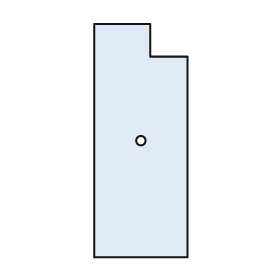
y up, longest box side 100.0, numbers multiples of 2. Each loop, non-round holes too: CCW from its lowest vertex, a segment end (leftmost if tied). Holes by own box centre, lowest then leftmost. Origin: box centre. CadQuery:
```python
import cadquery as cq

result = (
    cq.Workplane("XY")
    .moveTo(-20.0, -50.0)
    .lineTo(20.0, -50.0)
    .lineTo(20.0, 36.0)
    .lineTo(4.0, 36.0)
    .lineTo(4.0, 50.0)
    .lineTo(-20.0, 50.0)
    .close()
    .moveTo(0.0, 0.0)
    .circle(2.0)
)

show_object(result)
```